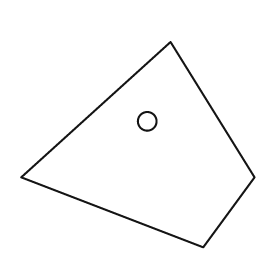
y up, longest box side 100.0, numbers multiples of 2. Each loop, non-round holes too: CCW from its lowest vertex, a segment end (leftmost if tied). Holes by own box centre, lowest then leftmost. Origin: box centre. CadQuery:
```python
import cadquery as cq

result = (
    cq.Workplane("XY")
    .moveTo(28.0, -44.0)
    .lineTo(50.0, -14.0)
    .lineTo(14.0, 44.0)
    .lineTo(-50.0, -14.0)
    .close()
    .moveTo(4.0, 10.0)
    .circle(4.0)
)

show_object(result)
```